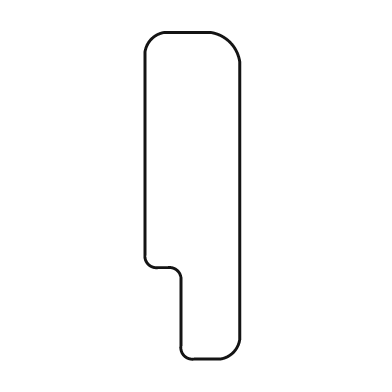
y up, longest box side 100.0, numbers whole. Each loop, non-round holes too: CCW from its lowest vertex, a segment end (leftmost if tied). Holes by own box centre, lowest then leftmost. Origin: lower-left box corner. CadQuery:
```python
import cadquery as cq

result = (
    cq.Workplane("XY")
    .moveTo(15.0, 0.0)
    .lineTo(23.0, 0.0)
    .threePointArc((27.0, 2.0), (29.0, 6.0))
    .lineTo(29.0, 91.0)
    .threePointArc((26.0, 97.0), (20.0, 100.0))
    .lineTo(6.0, 100.0)
    .threePointArc((2.0, 98.0), (0.0, 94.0))
    .lineTo(0.0, 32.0)
    .threePointArc((1.0, 29.0), (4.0, 28.0))
    .lineTo(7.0, 28.0)
    .threePointArc((10.0, 27.0), (11.0, 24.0))
    .lineTo(11.0, 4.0)
    .threePointArc((12.0, 1.0), (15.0, 0.0))
    .close()
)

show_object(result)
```